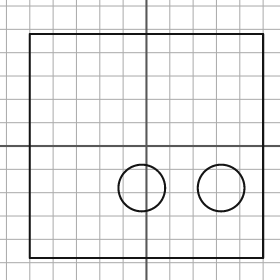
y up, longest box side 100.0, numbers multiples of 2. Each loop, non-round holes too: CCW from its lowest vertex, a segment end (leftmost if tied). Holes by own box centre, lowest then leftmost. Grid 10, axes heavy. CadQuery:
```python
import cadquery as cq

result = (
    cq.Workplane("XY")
    .moveTo(-50.0, -48.0)
    .lineTo(50.0, -48.0)
    .lineTo(50.0, 48.0)
    .lineTo(-50.0, 48.0)
    .close()
    .moveTo(-2.0, -18.0)
    .circle(10.0)
    .moveTo(32.0, -18.0)
    .circle(10.0)
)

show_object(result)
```